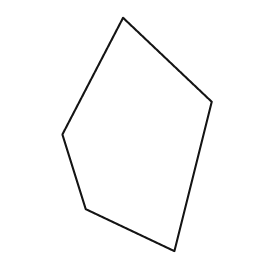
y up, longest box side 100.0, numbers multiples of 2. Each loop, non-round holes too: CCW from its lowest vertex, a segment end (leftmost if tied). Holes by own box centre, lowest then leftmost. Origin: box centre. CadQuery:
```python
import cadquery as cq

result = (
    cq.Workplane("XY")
    .moveTo(16.0, -50.0)
    .lineTo(32.0, 14.0)
    .lineTo(-6.0, 50.0)
    .lineTo(-32.0, 0.0)
    .lineTo(-22.0, -32.0)
    .close()
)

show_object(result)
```